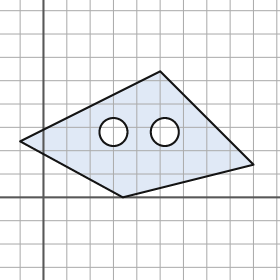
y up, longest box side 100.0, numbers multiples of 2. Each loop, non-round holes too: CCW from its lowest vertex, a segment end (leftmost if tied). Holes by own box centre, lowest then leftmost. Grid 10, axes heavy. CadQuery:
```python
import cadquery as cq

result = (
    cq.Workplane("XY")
    .moveTo(34.0, 0.0)
    .lineTo(90.0, 14.0)
    .lineTo(50.0, 54.0)
    .lineTo(-10.0, 24.0)
    .close()
    .moveTo(30.0, 28.0)
    .circle(6.0)
    .moveTo(52.0, 28.0)
    .circle(6.0)
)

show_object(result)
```